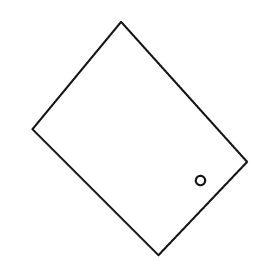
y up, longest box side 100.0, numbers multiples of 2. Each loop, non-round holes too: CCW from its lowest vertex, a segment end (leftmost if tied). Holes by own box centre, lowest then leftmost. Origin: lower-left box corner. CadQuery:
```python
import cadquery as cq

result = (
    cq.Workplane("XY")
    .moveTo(54.0, 0.0)
    .lineTo(92.0, 40.0)
    .lineTo(38.0, 100.0)
    .lineTo(0.0, 54.0)
    .close()
    .moveTo(72.0, 32.0)
    .circle(2.0)
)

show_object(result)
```